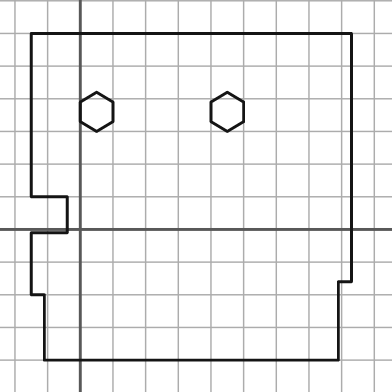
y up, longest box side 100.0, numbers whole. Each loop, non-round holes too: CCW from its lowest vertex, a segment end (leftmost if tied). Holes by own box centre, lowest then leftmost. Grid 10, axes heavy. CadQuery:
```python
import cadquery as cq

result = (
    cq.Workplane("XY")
    .moveTo(-11.0, -40.0)
    .lineTo(79.0, -40.0)
    .lineTo(79.0, -16.0)
    .lineTo(83.0, -16.0)
    .lineTo(83.0, 60.0)
    .lineTo(-15.0, 60.0)
    .lineTo(-15.0, 10.0)
    .lineTo(-4.0, 10.0)
    .lineTo(-4.0, -1.0)
    .lineTo(-15.0, -1.0)
    .lineTo(-15.0, -20.0)
    .lineTo(-11.0, -20.0)
    .close()
    .moveTo(5.0, 30.0)
    .lineTo(10.0, 33.0)
    .lineTo(10.0, 39.0)
    .lineTo(5.0, 42.0)
    .lineTo(0.0, 39.0)
    .lineTo(0.0, 33.0)
    .close()
    .moveTo(45.0, 30.0)
    .lineTo(50.0, 33.0)
    .lineTo(50.0, 39.0)
    .lineTo(45.0, 42.0)
    .lineTo(40.0, 39.0)
    .lineTo(40.0, 33.0)
    .close()
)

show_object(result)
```